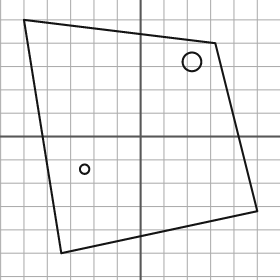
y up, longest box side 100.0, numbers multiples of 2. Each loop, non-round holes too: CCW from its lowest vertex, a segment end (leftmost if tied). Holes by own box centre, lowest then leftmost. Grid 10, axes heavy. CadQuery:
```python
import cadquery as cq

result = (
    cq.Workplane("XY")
    .moveTo(-34.0, -50.0)
    .lineTo(50.0, -32.0)
    .lineTo(32.0, 40.0)
    .lineTo(-50.0, 50.0)
    .close()
    .moveTo(-24.0, -14.0)
    .circle(2.0)
    .moveTo(22.0, 32.0)
    .circle(4.0)
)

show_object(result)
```